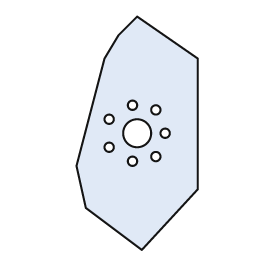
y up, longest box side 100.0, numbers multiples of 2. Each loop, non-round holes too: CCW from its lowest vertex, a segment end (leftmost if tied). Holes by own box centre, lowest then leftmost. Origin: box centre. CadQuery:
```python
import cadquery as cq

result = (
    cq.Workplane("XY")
    .moveTo(2.0, -50.0)
    .lineTo(26.0, -24.0)
    .lineTo(26.0, 32.0)
    .lineTo(0.0, 50.0)
    .lineTo(-8.0, 42.0)
    .lineTo(-14.0, 32.0)
    .lineTo(-26.0, -14.0)
    .lineTo(-22.0, -32.0)
    .close()
    .moveTo(-2.0, -12.0)
    .circle(2.0)
    .moveTo(8.0, -10.0)
    .circle(2.0)
    .moveTo(-12.0, -6.0)
    .circle(2.0)
    .moveTo(0.0, 0.0)
    .circle(6.0)
    .moveTo(12.0, 0.0)
    .circle(2.0)
    .moveTo(-12.0, 6.0)
    .circle(2.0)
    .moveTo(8.0, 10.0)
    .circle(2.0)
    .moveTo(-2.0, 12.0)
    .circle(2.0)
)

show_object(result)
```